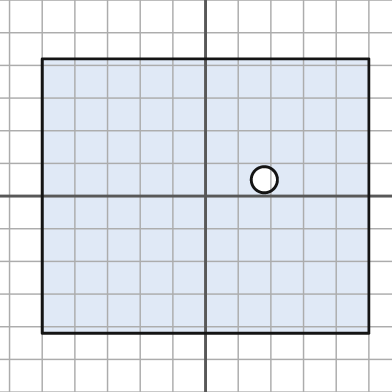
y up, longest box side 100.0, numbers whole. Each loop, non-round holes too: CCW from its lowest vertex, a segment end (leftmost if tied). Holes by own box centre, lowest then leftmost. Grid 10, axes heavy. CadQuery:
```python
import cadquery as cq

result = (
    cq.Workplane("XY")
    .moveTo(-50.0, -42.0)
    .lineTo(50.0, -42.0)
    .lineTo(50.0, 42.0)
    .lineTo(-50.0, 42.0)
    .close()
    .moveTo(18.0, 5.0)
    .circle(4.0)
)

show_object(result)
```